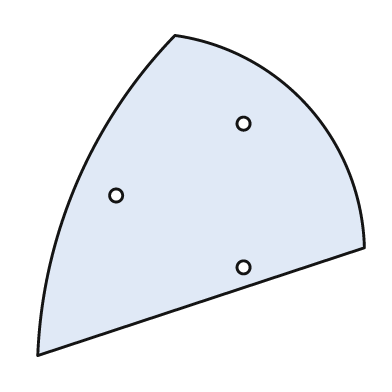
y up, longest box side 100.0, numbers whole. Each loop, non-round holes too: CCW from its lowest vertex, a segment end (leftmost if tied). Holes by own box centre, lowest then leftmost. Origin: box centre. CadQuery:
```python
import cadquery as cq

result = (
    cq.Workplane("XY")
    .moveTo(-50.0, -49.0)
    .lineTo(50.0, -16.0)
    .threePointArc((33.0, 27.0), (-8.0, 49.0))
    .threePointArc((-38.0, 4.0), (-50.0, -49.0))
    .close()
    .moveTo(13.0, -22.0)
    .circle(2.0)
    .moveTo(-26.0, 0.0)
    .circle(2.0)
    .moveTo(13.0, 22.0)
    .circle(2.0)
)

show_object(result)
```